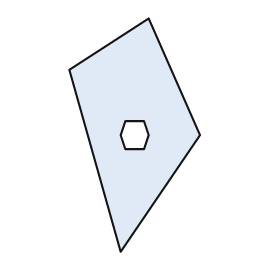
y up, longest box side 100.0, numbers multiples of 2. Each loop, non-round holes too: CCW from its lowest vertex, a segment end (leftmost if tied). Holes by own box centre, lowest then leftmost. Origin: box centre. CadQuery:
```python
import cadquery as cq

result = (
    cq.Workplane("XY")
    .moveTo(-6.0, -50.0)
    .lineTo(28.0, 0.0)
    .lineTo(6.0, 50.0)
    .lineTo(-28.0, 28.0)
    .close()
    .moveTo(-4.0, -6.0)
    .lineTo(4.0, -6.0)
    .lineTo(6.0, 0.0)
    .lineTo(4.0, 6.0)
    .lineTo(-4.0, 6.0)
    .lineTo(-6.0, 0.0)
    .close()
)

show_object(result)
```